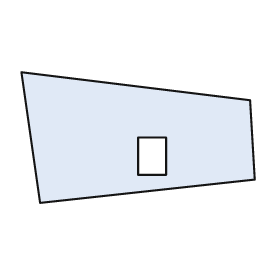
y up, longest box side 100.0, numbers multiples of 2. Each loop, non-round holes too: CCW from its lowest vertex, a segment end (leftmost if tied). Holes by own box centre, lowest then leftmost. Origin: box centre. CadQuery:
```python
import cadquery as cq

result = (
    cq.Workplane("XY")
    .moveTo(-42.0, -28.0)
    .lineTo(50.0, -18.0)
    .lineTo(48.0, 16.0)
    .lineTo(-50.0, 28.0)
    .close()
    .moveTo(0.0, -16.0)
    .lineTo(12.0, -16.0)
    .lineTo(12.0, 0.0)
    .lineTo(0.0, 0.0)
    .close()
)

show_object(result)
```